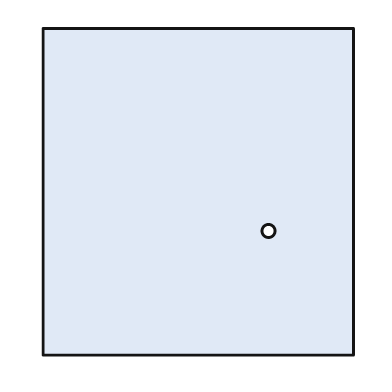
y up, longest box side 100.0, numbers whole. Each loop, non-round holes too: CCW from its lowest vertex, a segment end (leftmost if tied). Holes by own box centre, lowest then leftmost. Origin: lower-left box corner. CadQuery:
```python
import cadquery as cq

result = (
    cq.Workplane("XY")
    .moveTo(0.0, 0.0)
    .lineTo(95.0, 0.0)
    .lineTo(95.0, 100.0)
    .lineTo(0.0, 100.0)
    .close()
    .moveTo(69.0, 38.0)
    .circle(2.0)
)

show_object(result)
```